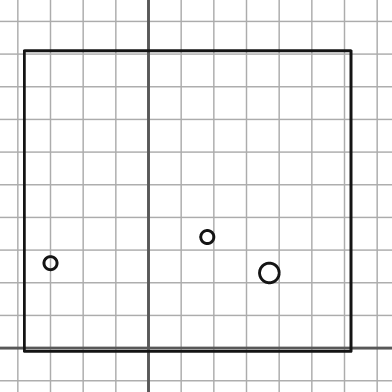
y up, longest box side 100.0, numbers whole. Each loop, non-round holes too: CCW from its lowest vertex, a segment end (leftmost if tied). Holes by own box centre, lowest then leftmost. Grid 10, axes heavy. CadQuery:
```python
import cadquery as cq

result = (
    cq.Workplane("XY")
    .moveTo(-38.0, -1.0)
    .lineTo(62.0, -1.0)
    .lineTo(62.0, 91.0)
    .lineTo(-38.0, 91.0)
    .close()
    .moveTo(37.0, 23.0)
    .circle(3.0)
    .moveTo(-30.0, 26.0)
    .circle(2.0)
    .moveTo(18.0, 34.0)
    .circle(2.0)
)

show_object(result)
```